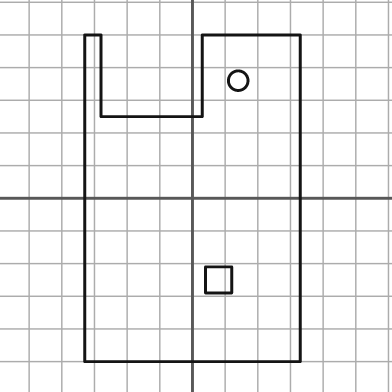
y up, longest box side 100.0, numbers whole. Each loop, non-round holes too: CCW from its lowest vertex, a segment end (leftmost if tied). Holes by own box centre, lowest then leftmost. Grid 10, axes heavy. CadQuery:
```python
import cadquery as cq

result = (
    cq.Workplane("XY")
    .moveTo(-33.0, -50.0)
    .lineTo(33.0, -50.0)
    .lineTo(33.0, 50.0)
    .lineTo(3.0, 50.0)
    .lineTo(3.0, 25.0)
    .lineTo(-28.0, 25.0)
    .lineTo(-28.0, 50.0)
    .lineTo(-33.0, 50.0)
    .close()
    .moveTo(4.0, -29.0)
    .lineTo(12.0, -29.0)
    .lineTo(12.0, -21.0)
    .lineTo(4.0, -21.0)
    .close()
    .moveTo(14.0, 36.0)
    .circle(3.0)
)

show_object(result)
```